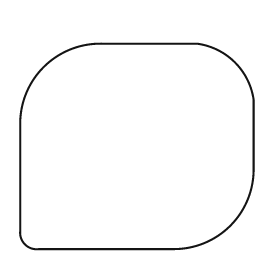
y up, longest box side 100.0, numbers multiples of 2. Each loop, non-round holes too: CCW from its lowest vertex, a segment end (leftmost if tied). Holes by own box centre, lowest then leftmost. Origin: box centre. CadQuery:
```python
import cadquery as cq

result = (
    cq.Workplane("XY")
    .moveTo(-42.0, -44.0)
    .lineTo(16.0, -44.0)
    .threePointArc((40.0, -34.0), (50.0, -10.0))
    .lineTo(50.0, 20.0)
    .threePointArc((42.0, 36.0), (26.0, 44.0))
    .lineTo(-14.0, 44.0)
    .threePointArc((-40.0, 34.0), (-50.0, 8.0))
    .lineTo(-50.0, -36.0)
    .threePointArc((-48.0, -42.0), (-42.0, -44.0))
    .close()
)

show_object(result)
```